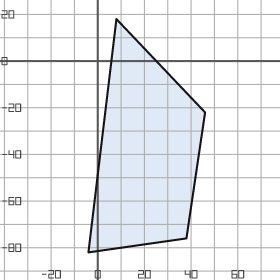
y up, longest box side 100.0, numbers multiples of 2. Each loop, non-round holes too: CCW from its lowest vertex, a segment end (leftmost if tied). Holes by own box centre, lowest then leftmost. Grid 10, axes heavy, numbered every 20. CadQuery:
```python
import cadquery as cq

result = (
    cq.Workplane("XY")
    .moveTo(-4.0, -82.0)
    .lineTo(38.0, -76.0)
    .lineTo(46.0, -22.0)
    .lineTo(8.0, 18.0)
    .close()
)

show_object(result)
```